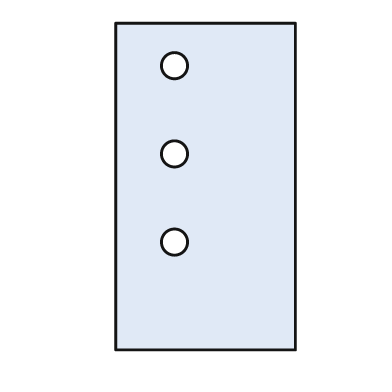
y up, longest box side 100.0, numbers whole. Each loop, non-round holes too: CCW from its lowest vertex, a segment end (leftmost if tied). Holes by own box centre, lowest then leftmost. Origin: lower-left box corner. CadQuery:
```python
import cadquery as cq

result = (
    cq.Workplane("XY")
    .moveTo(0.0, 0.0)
    .lineTo(55.0, 0.0)
    .lineTo(55.0, 100.0)
    .lineTo(0.0, 100.0)
    .close()
    .moveTo(18.0, 33.0)
    .circle(4.0)
    .moveTo(18.0, 60.0)
    .circle(4.0)
    .moveTo(18.0, 87.0)
    .circle(4.0)
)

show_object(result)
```